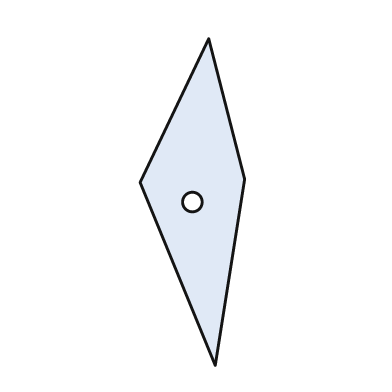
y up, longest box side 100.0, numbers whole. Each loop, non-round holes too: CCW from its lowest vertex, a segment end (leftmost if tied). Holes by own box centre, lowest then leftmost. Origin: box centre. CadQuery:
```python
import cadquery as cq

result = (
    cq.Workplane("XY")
    .moveTo(7.0, -50.0)
    .lineTo(16.0, 7.0)
    .lineTo(5.0, 50.0)
    .lineTo(-16.0, 6.0)
    .close()
    .moveTo(0.0, 0.0)
    .circle(3.0)
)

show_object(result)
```